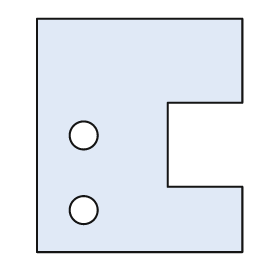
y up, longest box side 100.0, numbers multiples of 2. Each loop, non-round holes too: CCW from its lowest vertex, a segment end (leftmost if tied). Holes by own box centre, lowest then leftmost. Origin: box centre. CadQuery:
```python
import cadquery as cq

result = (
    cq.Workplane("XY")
    .moveTo(-44.0, -50.0)
    .lineTo(44.0, -50.0)
    .lineTo(44.0, -22.0)
    .lineTo(12.0, -22.0)
    .lineTo(12.0, 14.0)
    .lineTo(44.0, 14.0)
    .lineTo(44.0, 50.0)
    .lineTo(-44.0, 50.0)
    .close()
    .moveTo(-24.0, -32.0)
    .circle(6.0)
    .moveTo(-24.0, 0.0)
    .circle(6.0)
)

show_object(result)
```